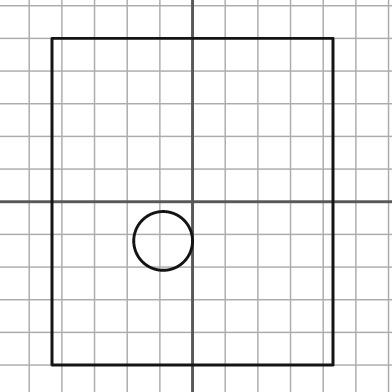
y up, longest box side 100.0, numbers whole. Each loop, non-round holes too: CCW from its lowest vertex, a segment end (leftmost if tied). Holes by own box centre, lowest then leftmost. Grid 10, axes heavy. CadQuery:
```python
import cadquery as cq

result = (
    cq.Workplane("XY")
    .moveTo(-43.0, -50.0)
    .lineTo(43.0, -50.0)
    .lineTo(43.0, 50.0)
    .lineTo(-43.0, 50.0)
    .close()
    .moveTo(-9.0, -12.0)
    .circle(9.0)
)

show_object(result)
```